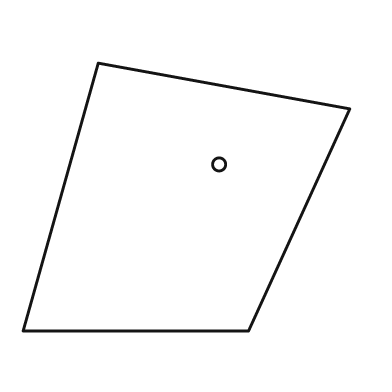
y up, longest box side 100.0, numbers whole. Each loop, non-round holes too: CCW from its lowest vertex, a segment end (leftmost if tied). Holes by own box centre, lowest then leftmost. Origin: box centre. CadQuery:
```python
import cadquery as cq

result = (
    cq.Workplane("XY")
    .moveTo(-50.0, -41.0)
    .lineTo(19.0, -41.0)
    .lineTo(50.0, 27.0)
    .lineTo(-27.0, 41.0)
    .close()
    .moveTo(10.0, 10.0)
    .circle(2.0)
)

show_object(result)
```